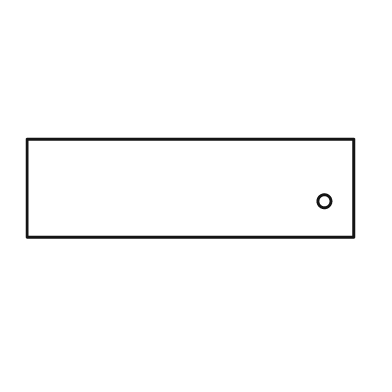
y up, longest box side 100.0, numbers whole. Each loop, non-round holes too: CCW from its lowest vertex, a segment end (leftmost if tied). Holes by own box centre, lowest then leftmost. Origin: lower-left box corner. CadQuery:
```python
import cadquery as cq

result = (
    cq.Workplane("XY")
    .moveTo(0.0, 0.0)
    .lineTo(100.0, 0.0)
    .lineTo(100.0, 30.0)
    .lineTo(0.0, 30.0)
    .close()
    .moveTo(91.0, 11.0)
    .circle(2.0)
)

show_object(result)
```